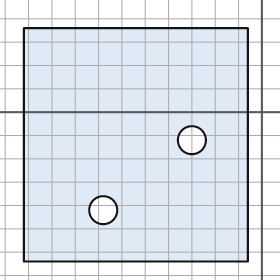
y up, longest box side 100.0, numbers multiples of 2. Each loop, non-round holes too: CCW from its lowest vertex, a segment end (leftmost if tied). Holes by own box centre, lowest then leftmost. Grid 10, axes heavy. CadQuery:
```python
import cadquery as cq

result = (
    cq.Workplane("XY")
    .moveTo(-102.0, -64.0)
    .lineTo(-6.0, -64.0)
    .lineTo(-6.0, 36.0)
    .lineTo(-102.0, 36.0)
    .close()
    .moveTo(-68.0, -42.0)
    .circle(6.0)
    .moveTo(-30.0, -12.0)
    .circle(6.0)
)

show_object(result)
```